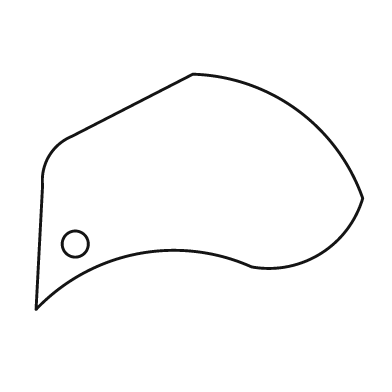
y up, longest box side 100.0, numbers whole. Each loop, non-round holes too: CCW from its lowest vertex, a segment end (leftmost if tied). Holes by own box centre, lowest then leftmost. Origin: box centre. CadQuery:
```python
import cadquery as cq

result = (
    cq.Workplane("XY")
    .moveTo(-50.0, -36.0)
    .threePointArc((-19.0, -19.0), (16.0, -23.0))
    .threePointArc((37.0, -19.0), (50.0, -2.0))
    .threePointArc((30.0, 25.0), (-2.0, 36.0))
    .lineTo(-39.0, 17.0)
    .threePointArc((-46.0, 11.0), (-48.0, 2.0))
    .close()
    .moveTo(-38.0, -16.0)
    .circle(4.0)
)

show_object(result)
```